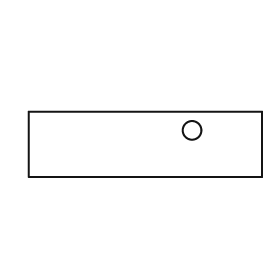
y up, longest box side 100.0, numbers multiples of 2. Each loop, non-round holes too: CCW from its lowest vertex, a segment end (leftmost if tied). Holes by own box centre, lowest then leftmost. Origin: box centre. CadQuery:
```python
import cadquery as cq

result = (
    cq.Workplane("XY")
    .moveTo(-50.0, -14.0)
    .lineTo(50.0, -14.0)
    .lineTo(50.0, 14.0)
    .lineTo(-50.0, 14.0)
    .close()
    .moveTo(20.0, 6.0)
    .circle(4.0)
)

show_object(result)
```